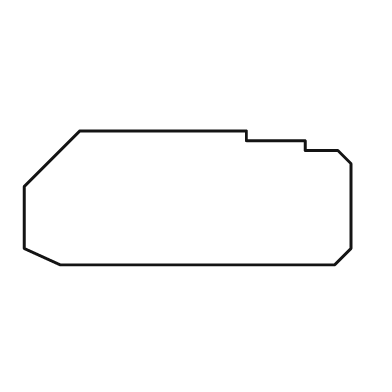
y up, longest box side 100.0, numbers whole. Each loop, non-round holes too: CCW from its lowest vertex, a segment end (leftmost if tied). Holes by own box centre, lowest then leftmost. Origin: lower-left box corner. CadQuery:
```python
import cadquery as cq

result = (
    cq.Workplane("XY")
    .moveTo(11.0, 0.0)
    .lineTo(95.0, 0.0)
    .lineTo(100.0, 5.0)
    .lineTo(100.0, 31.0)
    .lineTo(96.0, 35.0)
    .lineTo(86.0, 35.0)
    .lineTo(86.0, 38.0)
    .lineTo(68.0, 38.0)
    .lineTo(68.0, 41.0)
    .lineTo(17.0, 41.0)
    .lineTo(0.0, 24.0)
    .lineTo(0.0, 5.0)
    .close()
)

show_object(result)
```